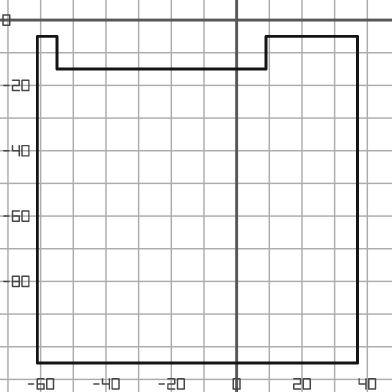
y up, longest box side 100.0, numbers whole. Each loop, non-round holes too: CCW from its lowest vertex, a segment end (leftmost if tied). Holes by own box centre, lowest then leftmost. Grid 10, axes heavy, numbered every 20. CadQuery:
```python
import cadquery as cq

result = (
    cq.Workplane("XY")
    .moveTo(-61.0, -105.0)
    .lineTo(37.0, -105.0)
    .lineTo(37.0, -5.0)
    .lineTo(9.0, -5.0)
    .lineTo(9.0, -15.0)
    .lineTo(-55.0, -15.0)
    .lineTo(-55.0, -5.0)
    .lineTo(-61.0, -5.0)
    .close()
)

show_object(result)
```